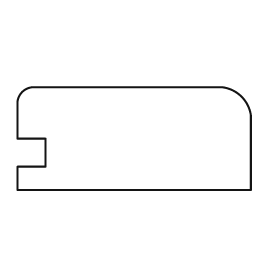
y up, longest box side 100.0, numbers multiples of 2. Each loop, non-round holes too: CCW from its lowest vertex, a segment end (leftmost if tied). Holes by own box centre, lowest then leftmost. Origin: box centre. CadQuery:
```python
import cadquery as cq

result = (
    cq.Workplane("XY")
    .moveTo(-50.0, -22.0)
    .lineTo(50.0, -22.0)
    .lineTo(50.0, 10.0)
    .threePointArc((46.0, 18.0), (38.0, 22.0))
    .lineTo(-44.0, 22.0)
    .threePointArc((-48.0, 20.0), (-50.0, 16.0))
    .lineTo(-50.0, 0.0)
    .lineTo(-38.0, 0.0)
    .lineTo(-38.0, -12.0)
    .lineTo(-50.0, -12.0)
    .close()
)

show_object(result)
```